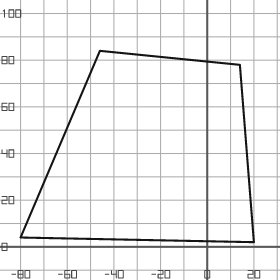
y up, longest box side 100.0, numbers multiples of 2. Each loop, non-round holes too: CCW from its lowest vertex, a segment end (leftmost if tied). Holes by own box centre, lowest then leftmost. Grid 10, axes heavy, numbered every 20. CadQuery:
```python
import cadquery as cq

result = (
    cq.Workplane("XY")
    .moveTo(20.0, 2.0)
    .lineTo(14.0, 78.0)
    .lineTo(-46.0, 84.0)
    .lineTo(-80.0, 4.0)
    .close()
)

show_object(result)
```